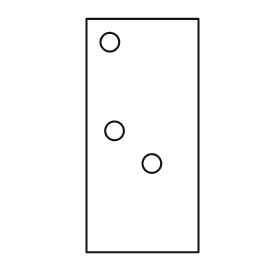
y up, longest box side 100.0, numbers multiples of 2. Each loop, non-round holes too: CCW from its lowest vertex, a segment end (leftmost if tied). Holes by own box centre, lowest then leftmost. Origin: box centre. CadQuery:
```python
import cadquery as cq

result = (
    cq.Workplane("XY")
    .moveTo(-24.0, -50.0)
    .lineTo(24.0, -50.0)
    .lineTo(24.0, 50.0)
    .lineTo(-24.0, 50.0)
    .close()
    .moveTo(4.0, -12.0)
    .circle(4.0)
    .moveTo(-12.0, 2.0)
    .circle(4.0)
    .moveTo(-14.0, 40.0)
    .circle(4.0)
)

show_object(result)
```